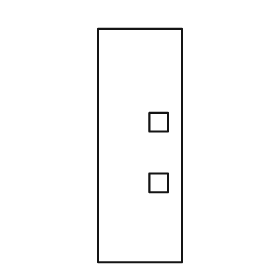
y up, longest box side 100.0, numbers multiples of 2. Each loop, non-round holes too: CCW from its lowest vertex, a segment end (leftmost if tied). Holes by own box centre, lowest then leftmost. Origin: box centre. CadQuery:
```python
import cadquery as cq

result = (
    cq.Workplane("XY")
    .moveTo(-18.0, -50.0)
    .lineTo(18.0, -50.0)
    .lineTo(18.0, 50.0)
    .lineTo(-18.0, 50.0)
    .close()
    .moveTo(4.0, -20.0)
    .lineTo(12.0, -20.0)
    .lineTo(12.0, -12.0)
    .lineTo(4.0, -12.0)
    .close()
    .moveTo(4.0, 6.0)
    .lineTo(12.0, 6.0)
    .lineTo(12.0, 14.0)
    .lineTo(4.0, 14.0)
    .close()
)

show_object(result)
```